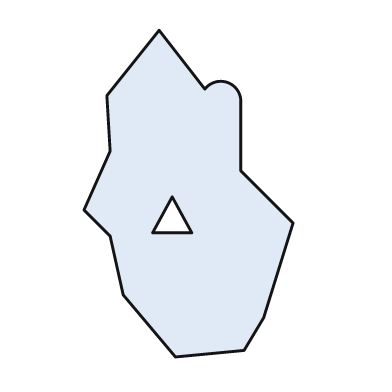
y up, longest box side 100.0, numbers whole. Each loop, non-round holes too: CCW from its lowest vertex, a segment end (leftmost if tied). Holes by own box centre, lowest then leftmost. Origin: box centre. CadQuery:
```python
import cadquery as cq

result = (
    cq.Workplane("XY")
    .moveTo(-4.0, -50.0)
    .lineTo(17.0, -48.0)
    .lineTo(23.0, -38.0)
    .lineTo(32.0, -9.0)
    .lineTo(16.0, 7.0)
    .lineTo(16.0, 28.0)
    .threePointArc((12.0, 34.0), (5.0, 32.0))
    .lineTo(-9.0, 50.0)
    .lineTo(-25.0, 30.0)
    .lineTo(-24.0, 13.0)
    .lineTo(-32.0, -5.0)
    .lineTo(-24.0, -13.0)
    .lineTo(-20.0, -31.0)
    .close()
    .moveTo(-11.0, -12.0)
    .lineTo(1.0, -12.0)
    .lineTo(-5.0, -1.0)
    .close()
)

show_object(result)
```